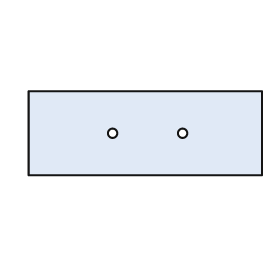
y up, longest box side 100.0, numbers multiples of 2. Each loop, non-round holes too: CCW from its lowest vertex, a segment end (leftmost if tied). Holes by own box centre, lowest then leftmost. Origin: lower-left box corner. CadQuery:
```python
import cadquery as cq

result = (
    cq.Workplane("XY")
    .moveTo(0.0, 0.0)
    .lineTo(100.0, 0.0)
    .lineTo(100.0, 36.0)
    .lineTo(0.0, 36.0)
    .close()
    .moveTo(36.0, 18.0)
    .circle(2.0)
    .moveTo(66.0, 18.0)
    .circle(2.0)
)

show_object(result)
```